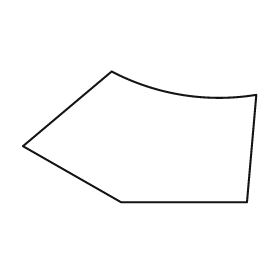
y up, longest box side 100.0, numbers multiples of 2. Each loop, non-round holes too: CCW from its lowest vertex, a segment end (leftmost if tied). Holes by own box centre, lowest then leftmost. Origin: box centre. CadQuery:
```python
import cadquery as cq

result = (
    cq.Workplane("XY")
    .moveTo(-8.0, -28.0)
    .lineTo(46.0, -28.0)
    .lineTo(50.0, 18.0)
    .threePointArc((18.0, 18.0), (-12.0, 28.0))
    .lineTo(-50.0, -4.0)
    .close()
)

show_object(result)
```